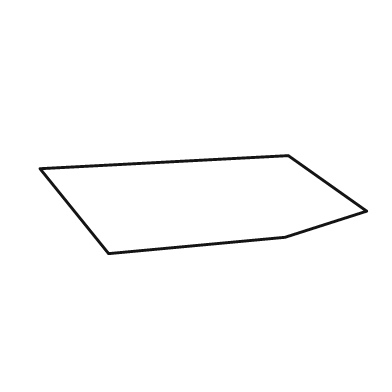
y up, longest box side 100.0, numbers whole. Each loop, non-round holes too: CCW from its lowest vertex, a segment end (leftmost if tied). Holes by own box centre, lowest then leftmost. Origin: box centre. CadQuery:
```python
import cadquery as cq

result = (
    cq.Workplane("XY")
    .moveTo(-29.0, -15.0)
    .lineTo(25.0, -10.0)
    .lineTo(50.0, -2.0)
    .lineTo(26.0, 15.0)
    .lineTo(-50.0, 11.0)
    .close()
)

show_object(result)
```